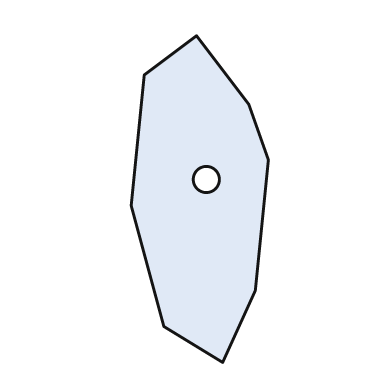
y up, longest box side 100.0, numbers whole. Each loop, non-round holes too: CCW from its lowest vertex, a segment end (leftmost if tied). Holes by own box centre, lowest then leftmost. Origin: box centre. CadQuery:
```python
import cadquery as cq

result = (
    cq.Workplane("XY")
    .moveTo(7.0, -50.0)
    .lineTo(17.0, -28.0)
    .lineTo(21.0, 12.0)
    .lineTo(15.0, 29.0)
    .lineTo(-1.0, 50.0)
    .lineTo(-17.0, 38.0)
    .lineTo(-21.0, -2.0)
    .lineTo(-11.0, -39.0)
    .close()
    .moveTo(2.0, 6.0)
    .circle(4.0)
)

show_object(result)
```